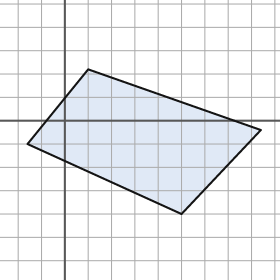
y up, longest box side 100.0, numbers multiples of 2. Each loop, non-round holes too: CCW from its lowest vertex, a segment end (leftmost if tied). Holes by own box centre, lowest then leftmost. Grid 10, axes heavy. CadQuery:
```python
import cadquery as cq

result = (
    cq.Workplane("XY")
    .moveTo(50.0, -40.0)
    .lineTo(84.0, -4.0)
    .lineTo(10.0, 22.0)
    .lineTo(-16.0, -10.0)
    .close()
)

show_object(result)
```